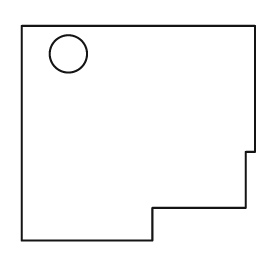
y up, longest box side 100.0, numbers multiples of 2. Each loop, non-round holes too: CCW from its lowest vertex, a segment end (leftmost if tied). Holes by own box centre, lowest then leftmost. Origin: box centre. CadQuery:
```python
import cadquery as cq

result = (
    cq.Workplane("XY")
    .moveTo(-50.0, -46.0)
    .lineTo(6.0, -46.0)
    .lineTo(6.0, -32.0)
    .lineTo(46.0, -32.0)
    .lineTo(46.0, -8.0)
    .lineTo(50.0, -8.0)
    .lineTo(50.0, 46.0)
    .lineTo(-50.0, 46.0)
    .close()
    .moveTo(-30.0, 34.0)
    .circle(8.0)
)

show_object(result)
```